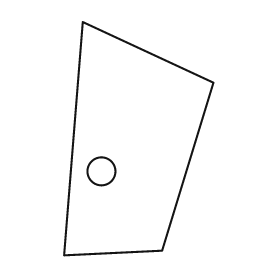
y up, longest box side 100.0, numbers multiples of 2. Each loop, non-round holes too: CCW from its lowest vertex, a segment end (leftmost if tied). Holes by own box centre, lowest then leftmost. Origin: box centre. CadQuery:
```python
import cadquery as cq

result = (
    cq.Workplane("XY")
    .moveTo(-32.0, -50.0)
    .lineTo(10.0, -48.0)
    .lineTo(32.0, 24.0)
    .lineTo(-24.0, 50.0)
    .close()
    .moveTo(-16.0, -14.0)
    .circle(6.0)
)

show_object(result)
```